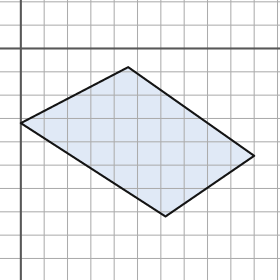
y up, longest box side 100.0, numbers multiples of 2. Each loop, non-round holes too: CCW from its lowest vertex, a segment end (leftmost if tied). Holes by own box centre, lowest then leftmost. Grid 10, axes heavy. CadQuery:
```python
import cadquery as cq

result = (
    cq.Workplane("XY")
    .moveTo(62.0, -72.0)
    .lineTo(100.0, -46.0)
    .lineTo(46.0, -8.0)
    .lineTo(0.0, -32.0)
    .close()
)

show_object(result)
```